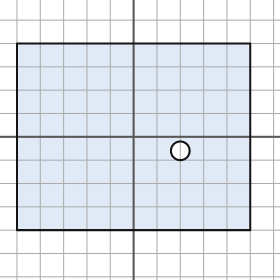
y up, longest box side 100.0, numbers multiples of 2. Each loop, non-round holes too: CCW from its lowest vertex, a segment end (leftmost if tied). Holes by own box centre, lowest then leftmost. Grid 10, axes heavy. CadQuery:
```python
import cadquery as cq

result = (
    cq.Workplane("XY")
    .moveTo(-50.0, -40.0)
    .lineTo(50.0, -40.0)
    .lineTo(50.0, 40.0)
    .lineTo(-50.0, 40.0)
    .close()
    .moveTo(20.0, -6.0)
    .circle(4.0)
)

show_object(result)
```